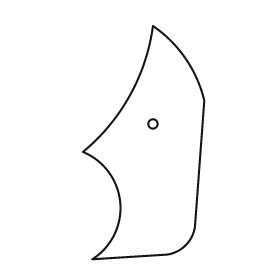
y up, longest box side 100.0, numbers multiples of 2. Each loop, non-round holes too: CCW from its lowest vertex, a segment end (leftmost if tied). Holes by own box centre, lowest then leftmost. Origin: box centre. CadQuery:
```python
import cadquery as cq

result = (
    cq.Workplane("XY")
    .moveTo(-22.0, -50.0)
    .lineTo(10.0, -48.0)
    .threePointArc((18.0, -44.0), (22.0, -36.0))
    .lineTo(26.0, 18.0)
    .threePointArc((18.0, 36.0), (4.0, 50.0))
    .threePointArc((-6.0, 20.0), (-26.0, -4.0))
    .threePointArc((-10.0, -26.0), (-22.0, -50.0))
    .close()
    .moveTo(4.0, 8.0)
    .circle(2.0)
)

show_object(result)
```